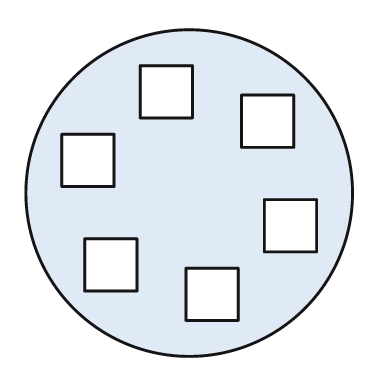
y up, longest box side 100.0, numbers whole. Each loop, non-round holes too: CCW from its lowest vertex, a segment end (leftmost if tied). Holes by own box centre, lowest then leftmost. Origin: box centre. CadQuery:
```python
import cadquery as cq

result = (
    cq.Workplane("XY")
    .moveTo(0.0, 0.0)
    .circle(50.0)
    .moveTo(-1.0, -39.0)
    .lineTo(15.0, -39.0)
    .lineTo(15.0, -23.0)
    .lineTo(-1.0, -23.0)
    .close()
    .moveTo(-32.0, -30.0)
    .lineTo(-16.0, -30.0)
    .lineTo(-16.0, -14.0)
    .lineTo(-32.0, -14.0)
    .close()
    .moveTo(23.0, -18.0)
    .lineTo(39.0, -18.0)
    .lineTo(39.0, -2.0)
    .lineTo(23.0, -2.0)
    .close()
    .moveTo(-39.0, 2.0)
    .lineTo(-23.0, 2.0)
    .lineTo(-23.0, 18.0)
    .lineTo(-39.0, 18.0)
    .close()
    .moveTo(16.0, 14.0)
    .lineTo(32.0, 14.0)
    .lineTo(32.0, 30.0)
    .lineTo(16.0, 30.0)
    .close()
    .moveTo(-15.0, 23.0)
    .lineTo(1.0, 23.0)
    .lineTo(1.0, 39.0)
    .lineTo(-15.0, 39.0)
    .close()
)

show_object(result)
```